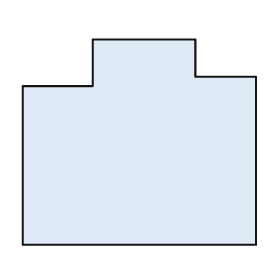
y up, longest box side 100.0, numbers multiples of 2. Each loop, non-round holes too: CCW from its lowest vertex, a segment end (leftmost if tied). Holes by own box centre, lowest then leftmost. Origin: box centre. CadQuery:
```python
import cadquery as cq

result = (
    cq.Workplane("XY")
    .moveTo(-50.0, -44.0)
    .lineTo(50.0, -44.0)
    .lineTo(50.0, 28.0)
    .lineTo(24.0, 28.0)
    .lineTo(24.0, 44.0)
    .lineTo(-20.0, 44.0)
    .lineTo(-20.0, 24.0)
    .lineTo(-50.0, 24.0)
    .close()
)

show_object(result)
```